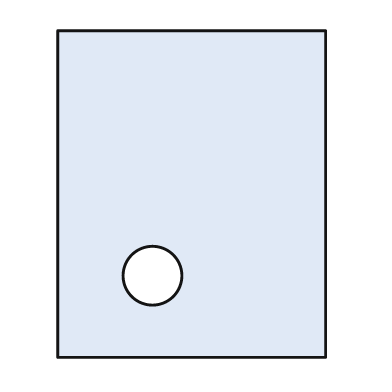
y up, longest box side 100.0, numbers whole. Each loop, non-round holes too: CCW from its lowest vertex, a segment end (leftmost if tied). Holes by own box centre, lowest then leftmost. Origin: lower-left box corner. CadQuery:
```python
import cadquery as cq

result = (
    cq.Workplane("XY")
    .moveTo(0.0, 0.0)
    .lineTo(82.0, 0.0)
    .lineTo(82.0, 100.0)
    .lineTo(0.0, 100.0)
    .close()
    .moveTo(29.0, 25.0)
    .circle(9.0)
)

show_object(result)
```